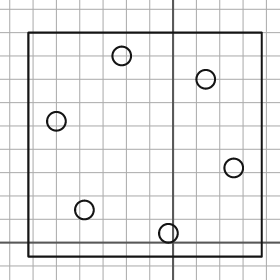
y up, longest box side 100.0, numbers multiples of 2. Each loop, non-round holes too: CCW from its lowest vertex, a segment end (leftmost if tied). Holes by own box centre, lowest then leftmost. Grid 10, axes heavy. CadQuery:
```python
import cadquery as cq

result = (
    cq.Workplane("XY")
    .moveTo(-62.0, -6.0)
    .lineTo(38.0, -6.0)
    .lineTo(38.0, 90.0)
    .lineTo(-62.0, 90.0)
    .close()
    .moveTo(-2.0, 4.0)
    .circle(4.0)
    .moveTo(-38.0, 14.0)
    .circle(4.0)
    .moveTo(26.0, 32.0)
    .circle(4.0)
    .moveTo(-50.0, 52.0)
    .circle(4.0)
    .moveTo(14.0, 70.0)
    .circle(4.0)
    .moveTo(-22.0, 80.0)
    .circle(4.0)
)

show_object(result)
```